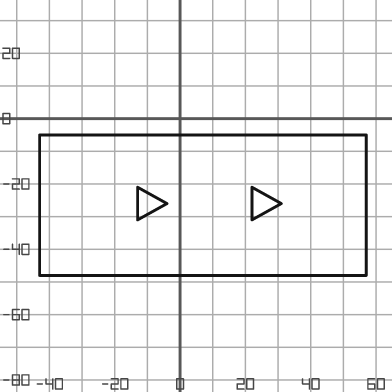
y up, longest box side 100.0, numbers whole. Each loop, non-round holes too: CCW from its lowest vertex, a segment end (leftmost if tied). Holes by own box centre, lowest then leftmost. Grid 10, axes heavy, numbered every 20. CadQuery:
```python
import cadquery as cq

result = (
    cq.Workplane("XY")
    .moveTo(-43.0, -48.0)
    .lineTo(57.0, -48.0)
    .lineTo(57.0, -5.0)
    .lineTo(-43.0, -5.0)
    .close()
    .moveTo(-13.0, -31.0)
    .lineTo(-4.0, -26.0)
    .lineTo(-13.0, -21.0)
    .close()
    .moveTo(22.0, -31.0)
    .lineTo(31.0, -26.0)
    .lineTo(22.0, -21.0)
    .close()
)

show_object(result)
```